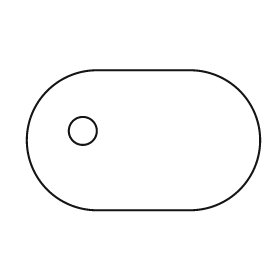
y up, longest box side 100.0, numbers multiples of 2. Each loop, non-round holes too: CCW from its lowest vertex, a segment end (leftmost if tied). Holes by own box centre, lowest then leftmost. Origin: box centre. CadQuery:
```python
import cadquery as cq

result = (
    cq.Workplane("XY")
    .moveTo(-20.0, -30.0)
    .lineTo(20.0, -30.0)
    .threePointArc((50.0, 0.0), (20.0, 30.0))
    .lineTo(-20.0, 30.0)
    .threePointArc((-50.0, 0.0), (-20.0, -30.0))
    .close()
    .moveTo(-26.0, 4.0)
    .circle(6.0)
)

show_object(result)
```